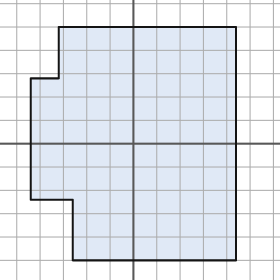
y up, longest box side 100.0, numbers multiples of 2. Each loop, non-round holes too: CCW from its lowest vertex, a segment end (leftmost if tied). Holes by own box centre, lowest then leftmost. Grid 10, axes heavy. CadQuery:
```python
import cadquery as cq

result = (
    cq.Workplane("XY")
    .moveTo(-26.0, -50.0)
    .lineTo(44.0, -50.0)
    .lineTo(44.0, 50.0)
    .lineTo(-32.0, 50.0)
    .lineTo(-32.0, 28.0)
    .lineTo(-44.0, 28.0)
    .lineTo(-44.0, -24.0)
    .lineTo(-26.0, -24.0)
    .close()
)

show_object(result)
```